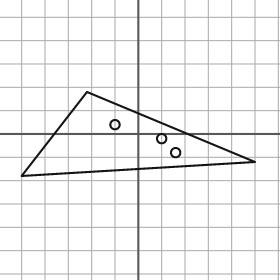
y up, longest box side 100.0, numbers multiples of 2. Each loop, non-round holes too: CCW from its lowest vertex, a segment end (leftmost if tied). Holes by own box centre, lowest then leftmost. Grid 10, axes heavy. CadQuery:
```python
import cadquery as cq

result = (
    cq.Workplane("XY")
    .moveTo(-50.0, -18.0)
    .lineTo(50.0, -12.0)
    .lineTo(-22.0, 18.0)
    .close()
    .moveTo(16.0, -8.0)
    .circle(2.0)
    .moveTo(10.0, -2.0)
    .circle(2.0)
    .moveTo(-10.0, 4.0)
    .circle(2.0)
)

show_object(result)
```